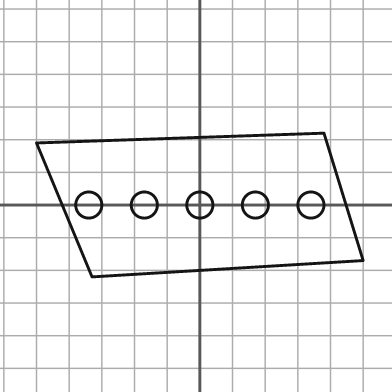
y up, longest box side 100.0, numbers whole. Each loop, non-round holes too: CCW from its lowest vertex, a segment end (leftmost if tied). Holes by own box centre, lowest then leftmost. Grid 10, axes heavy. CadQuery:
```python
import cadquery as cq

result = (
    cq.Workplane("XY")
    .moveTo(-33.0, -22.0)
    .lineTo(50.0, -17.0)
    .lineTo(38.0, 22.0)
    .lineTo(-50.0, 19.0)
    .close()
    .moveTo(-34.0, 0.0)
    .circle(4.0)
    .moveTo(-17.0, 0.0)
    .circle(4.0)
    .moveTo(0.0, 0.0)
    .circle(4.0)
    .moveTo(17.0, 0.0)
    .circle(4.0)
    .moveTo(34.0, 0.0)
    .circle(4.0)
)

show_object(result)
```